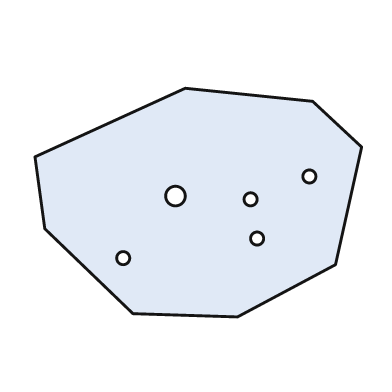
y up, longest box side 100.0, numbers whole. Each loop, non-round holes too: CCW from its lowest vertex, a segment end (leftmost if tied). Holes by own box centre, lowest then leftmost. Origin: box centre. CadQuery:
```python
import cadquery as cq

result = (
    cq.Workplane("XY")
    .moveTo(12.0, -35.0)
    .lineTo(42.0, -19.0)
    .lineTo(50.0, 17.0)
    .lineTo(35.0, 31.0)
    .lineTo(-4.0, 35.0)
    .lineTo(-50.0, 14.0)
    .lineTo(-47.0, -8.0)
    .lineTo(-20.0, -34.0)
    .close()
    .moveTo(-23.0, -17.0)
    .circle(2.0)
    .moveTo(18.0, -11.0)
    .circle(2.0)
    .moveTo(16.0, 1.0)
    .circle(2.0)
    .moveTo(-7.0, 2.0)
    .circle(3.0)
    .moveTo(34.0, 8.0)
    .circle(2.0)
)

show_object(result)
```